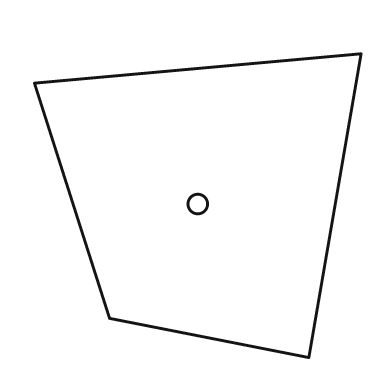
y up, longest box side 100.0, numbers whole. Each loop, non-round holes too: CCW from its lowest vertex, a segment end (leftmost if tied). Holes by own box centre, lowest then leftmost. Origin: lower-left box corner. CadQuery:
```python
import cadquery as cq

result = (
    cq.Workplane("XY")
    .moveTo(84.0, 0.0)
    .lineTo(100.0, 93.0)
    .lineTo(0.0, 84.0)
    .lineTo(23.0, 12.0)
    .close()
    .moveTo(50.0, 47.0)
    .circle(3.0)
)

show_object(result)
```